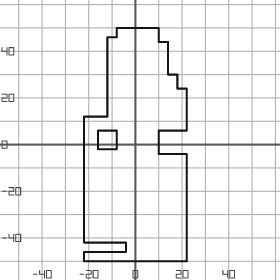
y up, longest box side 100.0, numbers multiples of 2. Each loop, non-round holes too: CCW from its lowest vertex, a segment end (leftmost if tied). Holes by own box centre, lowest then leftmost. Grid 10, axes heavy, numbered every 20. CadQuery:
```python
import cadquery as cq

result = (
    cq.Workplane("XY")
    .moveTo(-22.0, -50.0)
    .lineTo(22.0, -50.0)
    .lineTo(22.0, -4.0)
    .lineTo(10.0, -4.0)
    .lineTo(10.0, 6.0)
    .lineTo(22.0, 6.0)
    .lineTo(22.0, 24.0)
    .lineTo(18.0, 24.0)
    .lineTo(18.0, 30.0)
    .lineTo(14.0, 30.0)
    .lineTo(14.0, 44.0)
    .lineTo(10.0, 44.0)
    .lineTo(10.0, 50.0)
    .lineTo(-8.0, 50.0)
    .lineTo(-8.0, 46.0)
    .lineTo(-12.0, 46.0)
    .lineTo(-12.0, 12.0)
    .lineTo(-22.0, 12.0)
    .lineTo(-22.0, -42.0)
    .lineTo(-4.0, -42.0)
    .lineTo(-4.0, -46.0)
    .lineTo(-22.0, -46.0)
    .close()
    .moveTo(-16.0, -2.0)
    .lineTo(-8.0, -2.0)
    .lineTo(-8.0, 6.0)
    .lineTo(-16.0, 6.0)
    .close()
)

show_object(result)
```